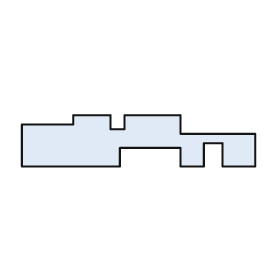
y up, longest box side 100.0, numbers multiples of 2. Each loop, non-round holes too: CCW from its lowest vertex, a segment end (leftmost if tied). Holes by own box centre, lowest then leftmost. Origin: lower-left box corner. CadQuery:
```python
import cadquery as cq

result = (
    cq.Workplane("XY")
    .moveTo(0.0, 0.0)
    .lineTo(42.0, 0.0)
    .lineTo(42.0, 8.0)
    .lineTo(68.0, 8.0)
    .lineTo(68.0, 0.0)
    .lineTo(78.0, 0.0)
    .lineTo(78.0, 10.0)
    .lineTo(86.0, 10.0)
    .lineTo(86.0, 0.0)
    .lineTo(100.0, 0.0)
    .lineTo(100.0, 14.0)
    .lineTo(68.0, 14.0)
    .lineTo(68.0, 22.0)
    .lineTo(44.0, 22.0)
    .lineTo(44.0, 16.0)
    .lineTo(38.0, 16.0)
    .lineTo(38.0, 22.0)
    .lineTo(22.0, 22.0)
    .lineTo(22.0, 18.0)
    .lineTo(0.0, 18.0)
    .close()
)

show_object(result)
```